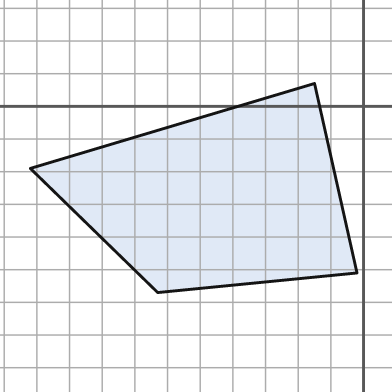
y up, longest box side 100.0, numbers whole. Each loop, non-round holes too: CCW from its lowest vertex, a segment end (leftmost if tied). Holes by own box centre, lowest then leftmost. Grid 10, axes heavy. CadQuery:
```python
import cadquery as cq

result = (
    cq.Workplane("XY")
    .moveTo(-63.0, -57.0)
    .lineTo(-2.0, -51.0)
    .lineTo(-15.0, 7.0)
    .lineTo(-102.0, -19.0)
    .close()
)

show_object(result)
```